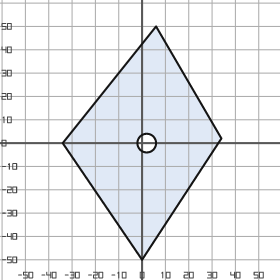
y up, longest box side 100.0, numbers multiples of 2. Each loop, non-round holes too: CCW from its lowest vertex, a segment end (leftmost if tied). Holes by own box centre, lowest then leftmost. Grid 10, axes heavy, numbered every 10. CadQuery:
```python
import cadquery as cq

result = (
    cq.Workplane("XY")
    .moveTo(0.0, -50.0)
    .lineTo(34.0, 2.0)
    .lineTo(6.0, 50.0)
    .lineTo(-34.0, 0.0)
    .close()
    .moveTo(2.0, 0.0)
    .circle(4.0)
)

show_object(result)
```